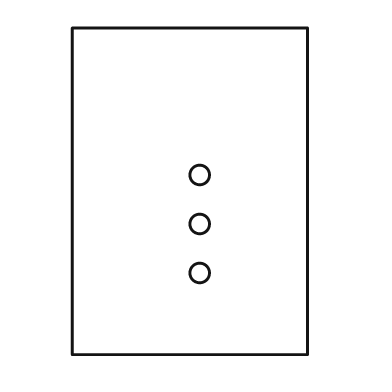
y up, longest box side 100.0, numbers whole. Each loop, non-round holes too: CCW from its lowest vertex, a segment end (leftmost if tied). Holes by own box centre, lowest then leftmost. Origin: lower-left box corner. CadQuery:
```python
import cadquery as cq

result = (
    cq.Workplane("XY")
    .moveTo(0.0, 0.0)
    .lineTo(72.0, 0.0)
    .lineTo(72.0, 100.0)
    .lineTo(0.0, 100.0)
    .close()
    .moveTo(39.0, 25.0)
    .circle(3.0)
    .moveTo(39.0, 40.0)
    .circle(3.0)
    .moveTo(39.0, 55.0)
    .circle(3.0)
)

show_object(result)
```